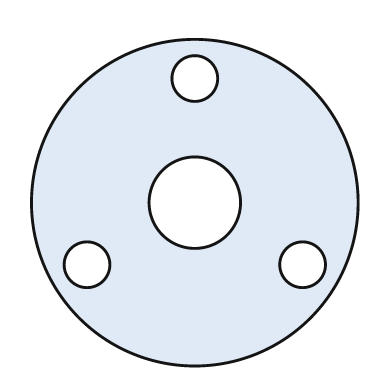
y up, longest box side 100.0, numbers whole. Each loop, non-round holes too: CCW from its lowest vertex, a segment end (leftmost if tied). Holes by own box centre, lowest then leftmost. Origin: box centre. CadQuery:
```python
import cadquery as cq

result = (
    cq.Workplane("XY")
    .moveTo(0.0, 0.0)
    .circle(50.0)
    .moveTo(-33.0, -19.0)
    .circle(7.0)
    .moveTo(33.0, -19.0)
    .circle(7.0)
    .moveTo(0.0, 0.0)
    .circle(14.0)
    .moveTo(0.0, 38.0)
    .circle(7.0)
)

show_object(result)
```